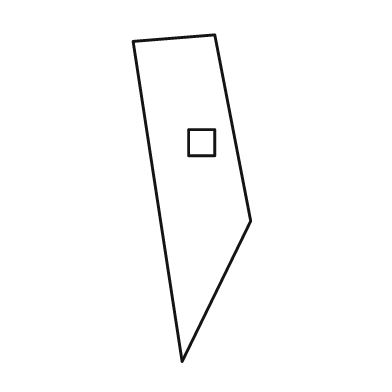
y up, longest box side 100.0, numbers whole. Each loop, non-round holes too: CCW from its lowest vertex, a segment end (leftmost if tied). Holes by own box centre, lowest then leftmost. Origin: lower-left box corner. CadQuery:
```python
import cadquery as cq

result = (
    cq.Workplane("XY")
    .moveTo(15.0, 0.0)
    .lineTo(36.0, 43.0)
    .lineTo(25.0, 100.0)
    .lineTo(0.0, 98.0)
    .close()
    .moveTo(17.0, 63.0)
    .lineTo(25.0, 63.0)
    .lineTo(25.0, 71.0)
    .lineTo(17.0, 71.0)
    .close()
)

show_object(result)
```